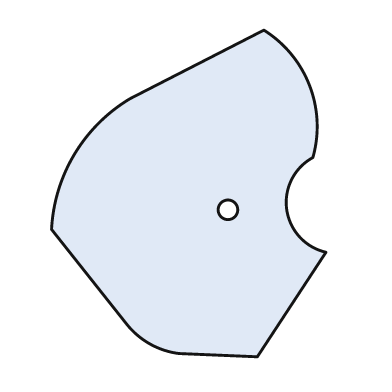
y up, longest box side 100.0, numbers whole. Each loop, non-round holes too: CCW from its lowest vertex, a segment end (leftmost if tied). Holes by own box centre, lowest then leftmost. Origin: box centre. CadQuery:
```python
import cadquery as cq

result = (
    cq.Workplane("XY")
    .moveTo(21.0, -50.0)
    .lineTo(42.0, -18.0)
    .threePointArc((30.0, -5.0), (38.0, 11.0))
    .threePointArc((37.0, 33.0), (23.0, 50.0))
    .lineTo(-18.0, 29.0)
    .threePointArc((-35.0, 12.0), (-42.0, -11.0))
    .lineTo(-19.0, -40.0)
    .threePointArc((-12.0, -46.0), (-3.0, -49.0))
    .close()
    .moveTo(12.0, -5.0)
    .circle(3.0)
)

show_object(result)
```